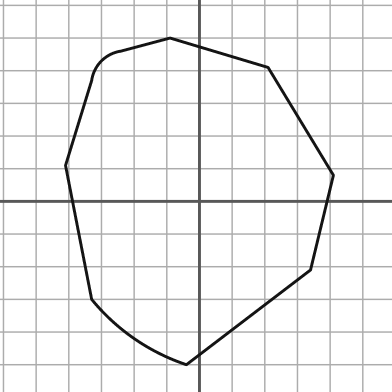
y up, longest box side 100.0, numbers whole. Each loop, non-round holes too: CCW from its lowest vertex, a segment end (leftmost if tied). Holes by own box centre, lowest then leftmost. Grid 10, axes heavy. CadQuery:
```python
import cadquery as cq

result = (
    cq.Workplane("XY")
    .moveTo(-4.0, -50.0)
    .lineTo(34.0, -21.0)
    .lineTo(41.0, 8.0)
    .lineTo(21.0, 41.0)
    .lineTo(-9.0, 50.0)
    .lineTo(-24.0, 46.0)
    .threePointArc((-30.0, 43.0), (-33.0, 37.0))
    .lineTo(-41.0, 11.0)
    .lineTo(-33.0, -30.0)
    .threePointArc((-20.0, -42.0), (-4.0, -50.0))
    .close()
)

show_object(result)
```